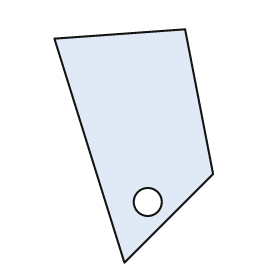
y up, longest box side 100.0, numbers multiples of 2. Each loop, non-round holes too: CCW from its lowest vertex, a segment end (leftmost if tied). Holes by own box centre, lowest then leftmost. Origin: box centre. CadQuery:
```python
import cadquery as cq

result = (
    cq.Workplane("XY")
    .moveTo(-4.0, -50.0)
    .lineTo(34.0, -12.0)
    .lineTo(22.0, 50.0)
    .lineTo(-34.0, 46.0)
    .close()
    .moveTo(6.0, -24.0)
    .circle(6.0)
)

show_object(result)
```